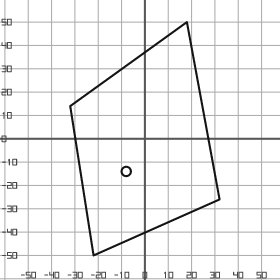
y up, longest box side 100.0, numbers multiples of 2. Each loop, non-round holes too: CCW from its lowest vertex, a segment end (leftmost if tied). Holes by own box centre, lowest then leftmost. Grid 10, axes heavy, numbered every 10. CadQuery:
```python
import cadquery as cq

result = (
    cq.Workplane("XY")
    .moveTo(-22.0, -50.0)
    .lineTo(32.0, -26.0)
    .lineTo(18.0, 50.0)
    .lineTo(-32.0, 14.0)
    .close()
    .moveTo(-8.0, -14.0)
    .circle(2.0)
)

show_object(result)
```